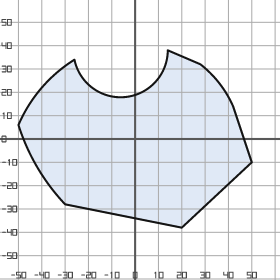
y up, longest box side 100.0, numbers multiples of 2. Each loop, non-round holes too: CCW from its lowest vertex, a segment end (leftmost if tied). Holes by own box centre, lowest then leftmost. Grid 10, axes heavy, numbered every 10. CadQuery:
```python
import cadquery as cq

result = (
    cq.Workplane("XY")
    .moveTo(20.0, -38.0)
    .lineTo(50.0, -10.0)
    .lineTo(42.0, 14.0)
    .threePointArc((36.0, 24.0), (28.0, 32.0))
    .lineTo(14.0, 38.0)
    .threePointArc((-4.0, 18.0), (-26.0, 34.0))
    .threePointArc((-40.0, 22.0), (-50.0, 6.0))
    .threePointArc((-42.0, -12.0), (-30.0, -28.0))
    .close()
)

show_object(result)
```